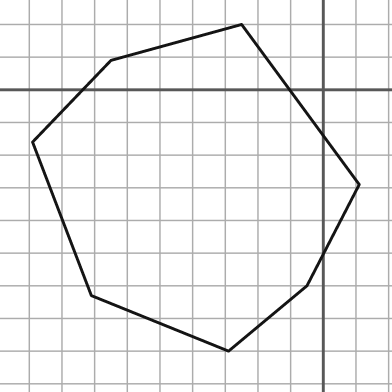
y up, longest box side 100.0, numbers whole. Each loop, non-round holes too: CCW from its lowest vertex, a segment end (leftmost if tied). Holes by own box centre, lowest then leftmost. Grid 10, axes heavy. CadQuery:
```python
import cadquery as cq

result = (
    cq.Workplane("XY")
    .moveTo(-29.0, -80.0)
    .lineTo(-5.0, -60.0)
    .lineTo(11.0, -29.0)
    .lineTo(-25.0, 20.0)
    .lineTo(-65.0, 9.0)
    .lineTo(-89.0, -16.0)
    .lineTo(-71.0, -63.0)
    .close()
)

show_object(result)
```